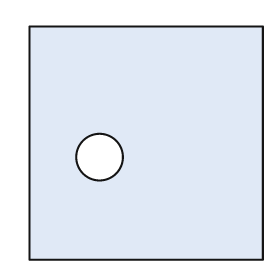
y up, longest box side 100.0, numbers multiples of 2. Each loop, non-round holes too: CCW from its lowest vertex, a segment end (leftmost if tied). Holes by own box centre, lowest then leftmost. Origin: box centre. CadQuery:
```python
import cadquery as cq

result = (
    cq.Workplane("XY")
    .moveTo(-50.0, -50.0)
    .lineTo(50.0, -50.0)
    .lineTo(50.0, 50.0)
    .lineTo(-50.0, 50.0)
    .close()
    .moveTo(-20.0, -6.0)
    .circle(10.0)
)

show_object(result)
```